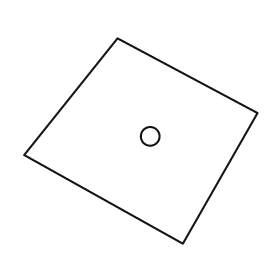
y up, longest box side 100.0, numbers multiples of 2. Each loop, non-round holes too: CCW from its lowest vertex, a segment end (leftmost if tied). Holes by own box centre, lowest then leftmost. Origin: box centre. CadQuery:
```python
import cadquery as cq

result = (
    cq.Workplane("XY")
    .moveTo(18.0, -44.0)
    .lineTo(50.0, 12.0)
    .lineTo(-10.0, 44.0)
    .lineTo(-50.0, -6.0)
    .close()
    .moveTo(4.0, 2.0)
    .circle(4.0)
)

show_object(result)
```